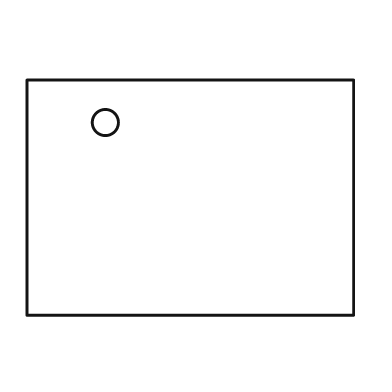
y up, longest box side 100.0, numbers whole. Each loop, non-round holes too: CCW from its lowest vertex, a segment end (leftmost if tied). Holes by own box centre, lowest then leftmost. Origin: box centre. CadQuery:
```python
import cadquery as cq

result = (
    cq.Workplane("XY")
    .moveTo(-50.0, -36.0)
    .lineTo(50.0, -36.0)
    .lineTo(50.0, 36.0)
    .lineTo(-50.0, 36.0)
    .close()
    .moveTo(-26.0, 23.0)
    .circle(4.0)
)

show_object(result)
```